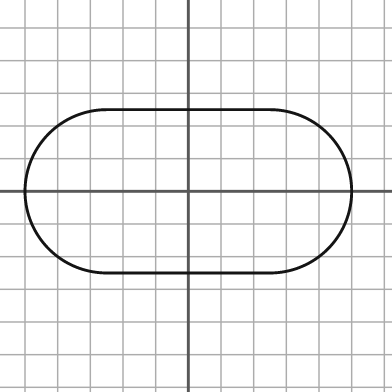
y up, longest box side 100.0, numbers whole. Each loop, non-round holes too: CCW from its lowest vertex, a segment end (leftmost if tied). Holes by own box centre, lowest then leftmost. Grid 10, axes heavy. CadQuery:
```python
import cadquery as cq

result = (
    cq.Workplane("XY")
    .moveTo(-25.0, -25.0)
    .lineTo(25.0, -25.0)
    .threePointArc((50.0, 0.0), (25.0, 25.0))
    .lineTo(-25.0, 25.0)
    .threePointArc((-50.0, 0.0), (-25.0, -25.0))
    .close()
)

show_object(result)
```